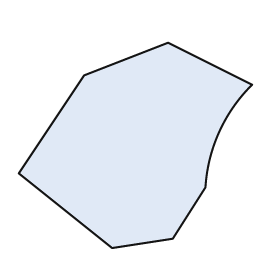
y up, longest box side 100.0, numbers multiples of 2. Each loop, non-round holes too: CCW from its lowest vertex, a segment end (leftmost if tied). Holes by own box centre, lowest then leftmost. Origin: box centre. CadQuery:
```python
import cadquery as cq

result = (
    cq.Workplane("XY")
    .moveTo(-10.0, -44.0)
    .lineTo(16.0, -40.0)
    .lineTo(30.0, -18.0)
    .threePointArc((36.0, 6.0), (50.0, 26.0))
    .lineTo(14.0, 44.0)
    .lineTo(-22.0, 30.0)
    .lineTo(-50.0, -12.0)
    .close()
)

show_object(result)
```